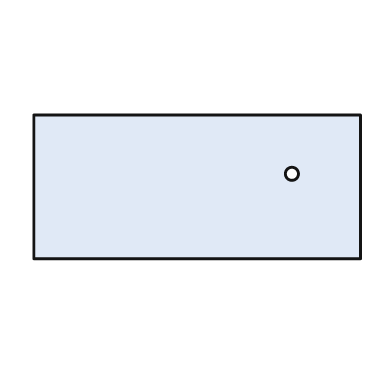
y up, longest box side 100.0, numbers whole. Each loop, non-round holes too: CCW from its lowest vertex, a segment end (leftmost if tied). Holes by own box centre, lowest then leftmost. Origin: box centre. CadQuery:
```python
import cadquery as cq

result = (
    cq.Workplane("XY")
    .moveTo(-50.0, -22.0)
    .lineTo(50.0, -22.0)
    .lineTo(50.0, 22.0)
    .lineTo(-50.0, 22.0)
    .close()
    .moveTo(29.0, 4.0)
    .circle(2.0)
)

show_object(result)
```